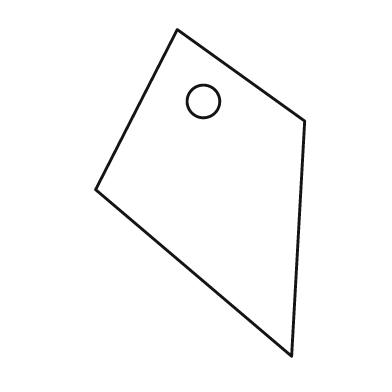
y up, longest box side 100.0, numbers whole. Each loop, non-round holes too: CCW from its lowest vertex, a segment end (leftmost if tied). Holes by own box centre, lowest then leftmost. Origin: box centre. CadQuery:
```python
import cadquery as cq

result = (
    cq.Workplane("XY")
    .moveTo(28.0, -50.0)
    .lineTo(32.0, 22.0)
    .lineTo(-7.0, 50.0)
    .lineTo(-32.0, 1.0)
    .close()
    .moveTo(1.0, 28.0)
    .circle(5.0)
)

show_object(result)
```